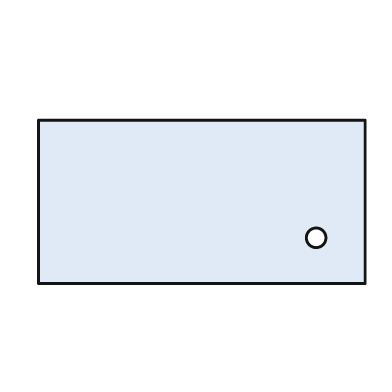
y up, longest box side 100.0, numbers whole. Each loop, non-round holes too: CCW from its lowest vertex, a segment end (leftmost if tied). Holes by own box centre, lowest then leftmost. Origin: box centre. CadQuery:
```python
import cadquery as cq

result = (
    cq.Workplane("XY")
    .moveTo(-50.0, -25.0)
    .lineTo(50.0, -25.0)
    .lineTo(50.0, 25.0)
    .lineTo(-50.0, 25.0)
    .close()
    .moveTo(35.0, -11.0)
    .circle(3.0)
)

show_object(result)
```